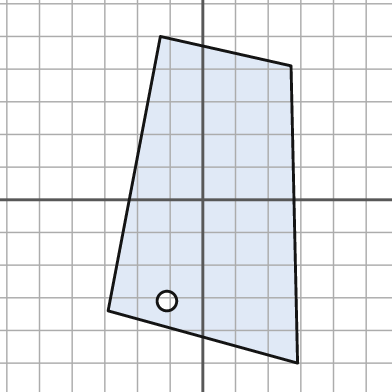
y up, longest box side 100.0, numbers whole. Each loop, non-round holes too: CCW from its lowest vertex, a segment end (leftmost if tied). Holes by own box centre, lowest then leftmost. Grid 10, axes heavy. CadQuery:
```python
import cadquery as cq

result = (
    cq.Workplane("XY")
    .moveTo(29.0, -50.0)
    .lineTo(27.0, 41.0)
    .lineTo(-13.0, 50.0)
    .lineTo(-29.0, -34.0)
    .close()
    .moveTo(-11.0, -31.0)
    .circle(3.0)
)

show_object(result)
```